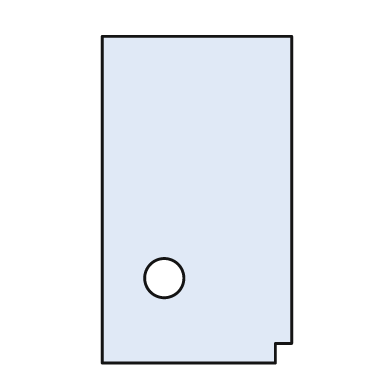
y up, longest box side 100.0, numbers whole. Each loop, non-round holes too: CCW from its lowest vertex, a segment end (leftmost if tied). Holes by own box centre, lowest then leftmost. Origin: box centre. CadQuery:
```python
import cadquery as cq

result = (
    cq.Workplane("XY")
    .moveTo(-29.0, -50.0)
    .lineTo(24.0, -50.0)
    .lineTo(24.0, -44.0)
    .lineTo(29.0, -44.0)
    .lineTo(29.0, 50.0)
    .lineTo(-29.0, 50.0)
    .close()
    .moveTo(-10.0, -24.0)
    .circle(6.0)
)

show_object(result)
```